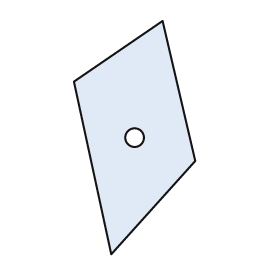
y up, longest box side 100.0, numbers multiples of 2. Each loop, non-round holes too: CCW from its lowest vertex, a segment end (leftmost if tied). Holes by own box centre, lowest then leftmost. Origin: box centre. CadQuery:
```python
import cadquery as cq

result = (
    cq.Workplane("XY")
    .moveTo(-10.0, -50.0)
    .lineTo(26.0, -10.0)
    .lineTo(12.0, 50.0)
    .lineTo(-26.0, 24.0)
    .close()
    .moveTo(0.0, 0.0)
    .circle(4.0)
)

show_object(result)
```